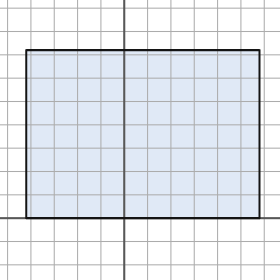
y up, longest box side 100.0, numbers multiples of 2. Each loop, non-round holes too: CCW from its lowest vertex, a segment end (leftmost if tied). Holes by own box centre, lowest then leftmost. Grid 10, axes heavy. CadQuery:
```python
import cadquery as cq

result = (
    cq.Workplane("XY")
    .moveTo(-42.0, 0.0)
    .lineTo(58.0, 0.0)
    .lineTo(58.0, 72.0)
    .lineTo(-42.0, 72.0)
    .close()
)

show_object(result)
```